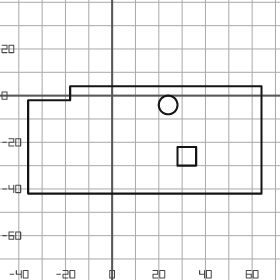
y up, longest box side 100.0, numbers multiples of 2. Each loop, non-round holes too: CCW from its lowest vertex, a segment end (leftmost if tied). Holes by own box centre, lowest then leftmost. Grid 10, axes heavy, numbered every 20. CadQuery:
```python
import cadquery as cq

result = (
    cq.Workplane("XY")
    .moveTo(-36.0, -42.0)
    .lineTo(64.0, -42.0)
    .lineTo(64.0, 4.0)
    .lineTo(-18.0, 4.0)
    .lineTo(-18.0, -2.0)
    .lineTo(-36.0, -2.0)
    .close()
    .moveTo(28.0, -30.0)
    .lineTo(36.0, -30.0)
    .lineTo(36.0, -22.0)
    .lineTo(28.0, -22.0)
    .close()
    .moveTo(24.0, -4.0)
    .circle(4.0)
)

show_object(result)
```